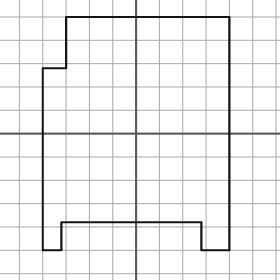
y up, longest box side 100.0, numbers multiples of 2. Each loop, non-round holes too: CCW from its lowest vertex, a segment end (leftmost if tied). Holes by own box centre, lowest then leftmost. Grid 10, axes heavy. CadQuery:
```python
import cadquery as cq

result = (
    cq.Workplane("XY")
    .moveTo(-40.0, -50.0)
    .lineTo(-32.0, -50.0)
    .lineTo(-32.0, -38.0)
    .lineTo(28.0, -38.0)
    .lineTo(28.0, -50.0)
    .lineTo(40.0, -50.0)
    .lineTo(40.0, 50.0)
    .lineTo(-30.0, 50.0)
    .lineTo(-30.0, 28.0)
    .lineTo(-40.0, 28.0)
    .close()
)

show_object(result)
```